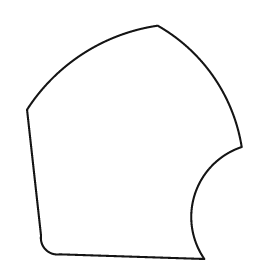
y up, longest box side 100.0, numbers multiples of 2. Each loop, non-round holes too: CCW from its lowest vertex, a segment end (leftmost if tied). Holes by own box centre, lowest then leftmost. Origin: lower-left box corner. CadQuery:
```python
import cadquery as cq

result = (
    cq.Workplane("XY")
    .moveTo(76.0, 0.0)
    .threePointArc((72.0, 28.0), (92.0, 48.0))
    .threePointArc((80.0, 78.0), (56.0, 100.0))
    .threePointArc((24.0, 88.0), (0.0, 64.0))
    .lineTo(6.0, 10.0)
    .threePointArc((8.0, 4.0), (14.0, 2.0))
    .close()
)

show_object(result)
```